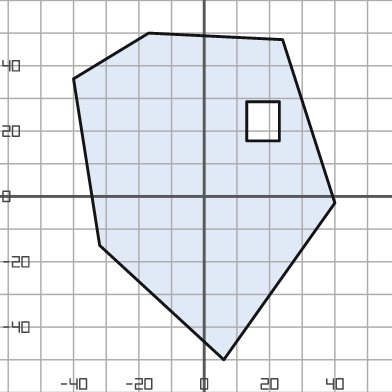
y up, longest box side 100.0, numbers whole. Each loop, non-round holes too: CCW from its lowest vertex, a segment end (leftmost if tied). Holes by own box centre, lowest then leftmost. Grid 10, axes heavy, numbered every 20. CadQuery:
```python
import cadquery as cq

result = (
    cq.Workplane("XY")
    .moveTo(6.0, -50.0)
    .lineTo(40.0, -2.0)
    .lineTo(24.0, 48.0)
    .lineTo(-17.0, 50.0)
    .lineTo(-40.0, 36.0)
    .lineTo(-32.0, -15.0)
    .close()
    .moveTo(13.0, 17.0)
    .lineTo(23.0, 17.0)
    .lineTo(23.0, 29.0)
    .lineTo(13.0, 29.0)
    .close()
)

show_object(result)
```